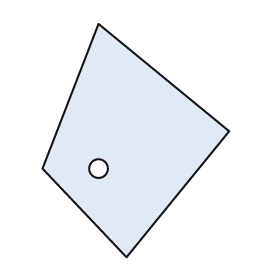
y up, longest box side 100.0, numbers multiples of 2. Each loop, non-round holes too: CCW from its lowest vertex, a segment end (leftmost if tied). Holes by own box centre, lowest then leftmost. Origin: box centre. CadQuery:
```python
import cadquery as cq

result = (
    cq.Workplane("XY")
    .moveTo(-4.0, -50.0)
    .lineTo(40.0, 4.0)
    .lineTo(-16.0, 50.0)
    .lineTo(-40.0, -12.0)
    .close()
    .moveTo(-16.0, -12.0)
    .circle(4.0)
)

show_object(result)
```